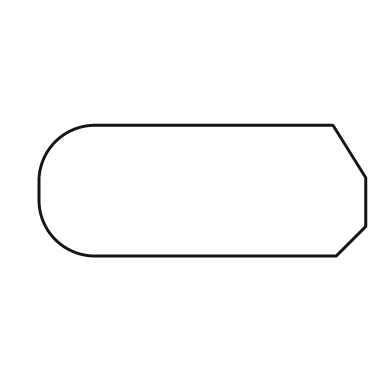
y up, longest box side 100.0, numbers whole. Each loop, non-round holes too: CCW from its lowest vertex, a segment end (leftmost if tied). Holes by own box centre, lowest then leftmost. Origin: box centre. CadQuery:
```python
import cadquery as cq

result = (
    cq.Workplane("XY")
    .moveTo(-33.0, -20.0)
    .lineTo(41.0, -20.0)
    .lineTo(50.0, -11.0)
    .lineTo(50.0, 4.0)
    .lineTo(40.0, 20.0)
    .lineTo(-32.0, 20.0)
    .threePointArc((-45.0, 15.0), (-50.0, 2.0))
    .lineTo(-50.0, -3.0)
    .threePointArc((-45.0, -15.0), (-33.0, -20.0))
    .close()
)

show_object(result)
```